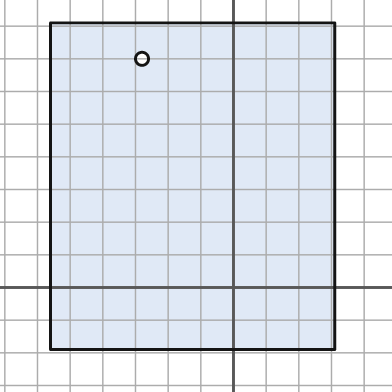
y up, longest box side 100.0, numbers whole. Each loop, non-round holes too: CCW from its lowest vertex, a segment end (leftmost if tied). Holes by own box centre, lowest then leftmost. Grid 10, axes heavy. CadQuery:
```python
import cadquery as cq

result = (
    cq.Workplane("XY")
    .moveTo(-56.0, -19.0)
    .lineTo(31.0, -19.0)
    .lineTo(31.0, 81.0)
    .lineTo(-56.0, 81.0)
    .close()
    .moveTo(-28.0, 70.0)
    .circle(2.0)
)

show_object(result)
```